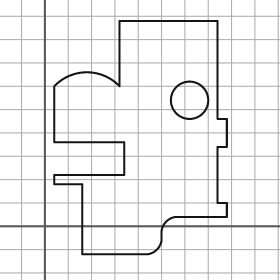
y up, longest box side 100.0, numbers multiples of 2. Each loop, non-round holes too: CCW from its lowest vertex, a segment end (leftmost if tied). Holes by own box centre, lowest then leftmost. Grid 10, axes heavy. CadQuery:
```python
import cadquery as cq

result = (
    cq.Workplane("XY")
    .moveTo(16.0, -12.0)
    .lineTo(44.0, -12.0)
    .threePointArc((48.0, -10.0), (50.0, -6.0))
    .lineTo(50.0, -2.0)
    .threePointArc((52.0, 2.0), (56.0, 4.0))
    .lineTo(78.0, 4.0)
    .lineTo(78.0, 10.0)
    .lineTo(74.0, 10.0)
    .lineTo(74.0, 34.0)
    .lineTo(78.0, 34.0)
    .lineTo(78.0, 46.0)
    .lineTo(74.0, 46.0)
    .lineTo(74.0, 88.0)
    .lineTo(32.0, 88.0)
    .lineTo(32.0, 60.0)
    .threePointArc((18.0, 66.0), (4.0, 60.0))
    .lineTo(4.0, 36.0)
    .lineTo(34.0, 36.0)
    .lineTo(34.0, 22.0)
    .lineTo(4.0, 22.0)
    .lineTo(4.0, 18.0)
    .lineTo(16.0, 18.0)
    .close()
    .moveTo(62.0, 54.0)
    .circle(8.0)
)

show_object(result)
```